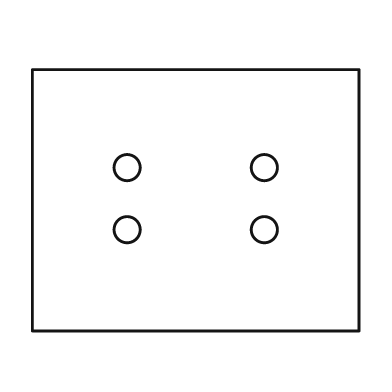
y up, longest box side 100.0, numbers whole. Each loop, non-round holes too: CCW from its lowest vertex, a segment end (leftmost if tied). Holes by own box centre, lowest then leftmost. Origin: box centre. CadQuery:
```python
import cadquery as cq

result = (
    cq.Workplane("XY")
    .moveTo(-50.0, -40.0)
    .lineTo(50.0, -40.0)
    .lineTo(50.0, 40.0)
    .lineTo(-50.0, 40.0)
    .close()
    .moveTo(-21.0, -9.0)
    .circle(4.0)
    .moveTo(21.0, -9.0)
    .circle(4.0)
    .moveTo(-21.0, 10.0)
    .circle(4.0)
    .moveTo(21.0, 10.0)
    .circle(4.0)
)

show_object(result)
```